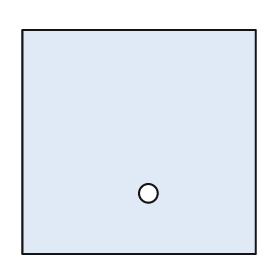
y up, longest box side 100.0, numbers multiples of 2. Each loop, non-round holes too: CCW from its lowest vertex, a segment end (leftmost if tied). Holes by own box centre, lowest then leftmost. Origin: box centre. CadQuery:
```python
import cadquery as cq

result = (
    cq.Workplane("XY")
    .moveTo(-50.0, -48.0)
    .lineTo(50.0, -48.0)
    .lineTo(50.0, 48.0)
    .lineTo(-50.0, 48.0)
    .close()
    .moveTo(4.0, -22.0)
    .circle(4.0)
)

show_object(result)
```